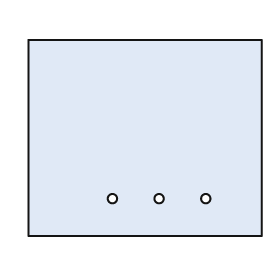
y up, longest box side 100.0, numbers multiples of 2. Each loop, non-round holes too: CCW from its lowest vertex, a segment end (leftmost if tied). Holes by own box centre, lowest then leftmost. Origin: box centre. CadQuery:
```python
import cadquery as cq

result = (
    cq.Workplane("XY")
    .moveTo(-50.0, -42.0)
    .lineTo(50.0, -42.0)
    .lineTo(50.0, 42.0)
    .lineTo(-50.0, 42.0)
    .close()
    .moveTo(-14.0, -26.0)
    .circle(2.0)
    .moveTo(6.0, -26.0)
    .circle(2.0)
    .moveTo(26.0, -26.0)
    .circle(2.0)
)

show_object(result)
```